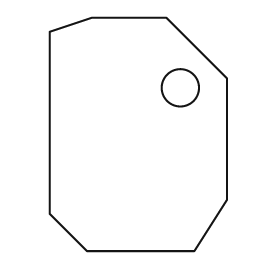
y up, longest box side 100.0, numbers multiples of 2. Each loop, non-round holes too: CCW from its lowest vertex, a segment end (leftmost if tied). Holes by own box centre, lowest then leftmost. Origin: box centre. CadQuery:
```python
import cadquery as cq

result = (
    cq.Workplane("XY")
    .moveTo(-22.0, -50.0)
    .lineTo(24.0, -50.0)
    .lineTo(38.0, -28.0)
    .lineTo(38.0, 24.0)
    .lineTo(12.0, 50.0)
    .lineTo(-20.0, 50.0)
    .lineTo(-38.0, 44.0)
    .lineTo(-38.0, -34.0)
    .close()
    .moveTo(18.0, 20.0)
    .circle(8.0)
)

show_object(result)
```